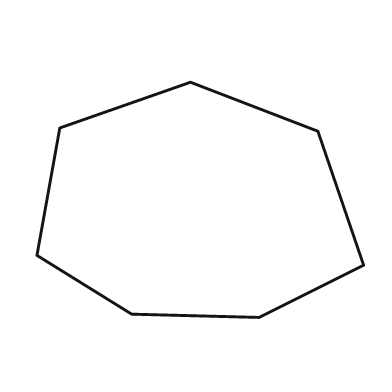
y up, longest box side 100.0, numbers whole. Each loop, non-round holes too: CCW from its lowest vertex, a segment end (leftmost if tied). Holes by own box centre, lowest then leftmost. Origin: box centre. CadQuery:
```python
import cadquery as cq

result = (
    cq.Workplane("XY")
    .moveTo(18.0, -36.0)
    .lineTo(50.0, -20.0)
    .lineTo(36.0, 21.0)
    .lineTo(-3.0, 36.0)
    .lineTo(-43.0, 22.0)
    .lineTo(-50.0, -17.0)
    .lineTo(-21.0, -35.0)
    .close()
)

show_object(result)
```